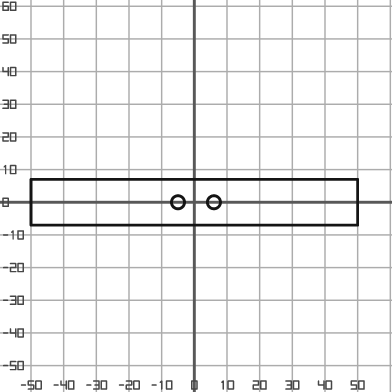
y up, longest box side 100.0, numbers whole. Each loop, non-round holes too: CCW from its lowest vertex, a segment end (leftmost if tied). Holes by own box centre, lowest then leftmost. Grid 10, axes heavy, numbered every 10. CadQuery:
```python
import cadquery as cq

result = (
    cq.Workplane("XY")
    .moveTo(-50.0, -7.0)
    .lineTo(50.0, -7.0)
    .lineTo(50.0, 7.0)
    .lineTo(-50.0, 7.0)
    .close()
    .moveTo(-5.0, 0.0)
    .circle(2.0)
    .moveTo(6.0, 0.0)
    .circle(2.0)
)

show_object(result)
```